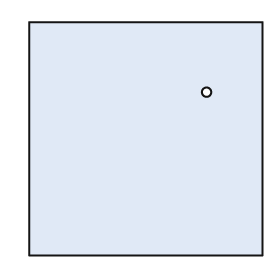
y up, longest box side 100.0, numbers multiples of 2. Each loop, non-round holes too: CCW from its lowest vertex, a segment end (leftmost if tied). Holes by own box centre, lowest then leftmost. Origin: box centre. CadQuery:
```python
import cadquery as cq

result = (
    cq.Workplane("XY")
    .moveTo(-50.0, -50.0)
    .lineTo(50.0, -50.0)
    .lineTo(50.0, 50.0)
    .lineTo(-50.0, 50.0)
    .close()
    .moveTo(26.0, 20.0)
    .circle(2.0)
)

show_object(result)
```